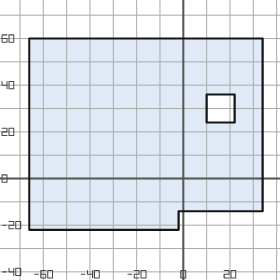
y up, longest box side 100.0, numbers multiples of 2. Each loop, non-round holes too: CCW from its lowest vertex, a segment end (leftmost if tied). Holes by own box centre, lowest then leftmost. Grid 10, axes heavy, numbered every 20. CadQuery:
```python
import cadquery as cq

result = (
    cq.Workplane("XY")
    .moveTo(-66.0, -22.0)
    .lineTo(-2.0, -22.0)
    .lineTo(-2.0, -14.0)
    .lineTo(34.0, -14.0)
    .lineTo(34.0, 60.0)
    .lineTo(-66.0, 60.0)
    .close()
    .moveTo(10.0, 24.0)
    .lineTo(22.0, 24.0)
    .lineTo(22.0, 36.0)
    .lineTo(10.0, 36.0)
    .close()
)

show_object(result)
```